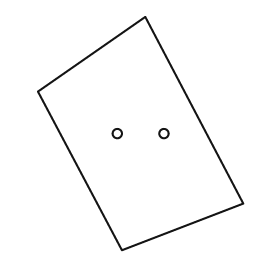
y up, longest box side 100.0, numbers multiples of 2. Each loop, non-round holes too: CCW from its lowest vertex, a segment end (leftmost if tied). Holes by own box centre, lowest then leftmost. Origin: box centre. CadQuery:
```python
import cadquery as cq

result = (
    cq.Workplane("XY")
    .moveTo(-8.0, -50.0)
    .lineTo(44.0, -30.0)
    .lineTo(2.0, 50.0)
    .lineTo(-44.0, 18.0)
    .close()
    .moveTo(-10.0, 0.0)
    .circle(2.0)
    .moveTo(10.0, 0.0)
    .circle(2.0)
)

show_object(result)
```